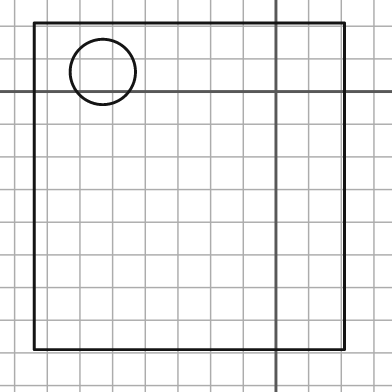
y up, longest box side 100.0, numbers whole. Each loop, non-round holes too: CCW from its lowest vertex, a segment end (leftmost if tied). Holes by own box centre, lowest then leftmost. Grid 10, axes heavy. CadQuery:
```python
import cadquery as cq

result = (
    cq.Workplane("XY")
    .moveTo(-74.0, -79.0)
    .lineTo(21.0, -79.0)
    .lineTo(21.0, 21.0)
    .lineTo(-74.0, 21.0)
    .close()
    .moveTo(-53.0, 6.0)
    .circle(10.0)
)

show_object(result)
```